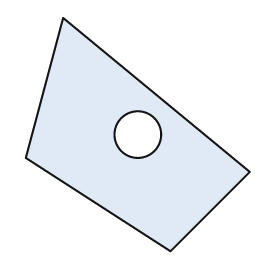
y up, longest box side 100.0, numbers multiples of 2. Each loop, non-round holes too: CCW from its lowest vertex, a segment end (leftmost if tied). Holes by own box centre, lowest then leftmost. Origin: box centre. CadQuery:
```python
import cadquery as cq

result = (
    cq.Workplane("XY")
    .moveTo(14.0, -50.0)
    .lineTo(48.0, -16.0)
    .lineTo(-32.0, 50.0)
    .lineTo(-48.0, -10.0)
    .close()
    .moveTo(0.0, 0.0)
    .circle(10.0)
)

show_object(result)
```